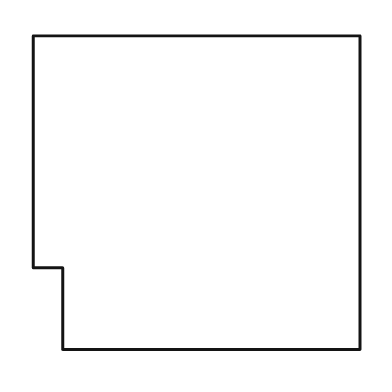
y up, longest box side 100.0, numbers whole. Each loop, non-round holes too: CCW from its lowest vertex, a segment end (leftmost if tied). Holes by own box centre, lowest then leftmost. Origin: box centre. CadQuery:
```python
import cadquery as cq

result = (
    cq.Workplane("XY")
    .moveTo(-41.0, -48.0)
    .lineTo(50.0, -48.0)
    .lineTo(50.0, 48.0)
    .lineTo(-50.0, 48.0)
    .lineTo(-50.0, -23.0)
    .lineTo(-41.0, -23.0)
    .close()
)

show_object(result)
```